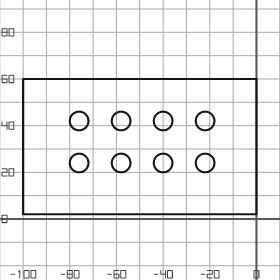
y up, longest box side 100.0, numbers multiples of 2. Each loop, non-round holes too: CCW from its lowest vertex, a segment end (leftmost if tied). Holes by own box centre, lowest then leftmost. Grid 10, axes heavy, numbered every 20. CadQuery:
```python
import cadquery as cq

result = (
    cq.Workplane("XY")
    .moveTo(-100.0, 2.0)
    .lineTo(0.0, 2.0)
    .lineTo(0.0, 60.0)
    .lineTo(-100.0, 60.0)
    .close()
    .moveTo(-76.0, 24.0)
    .circle(4.0)
    .moveTo(-58.0, 24.0)
    .circle(4.0)
    .moveTo(-40.0, 24.0)
    .circle(4.0)
    .moveTo(-22.0, 24.0)
    .circle(4.0)
    .moveTo(-76.0, 42.0)
    .circle(4.0)
    .moveTo(-58.0, 42.0)
    .circle(4.0)
    .moveTo(-40.0, 42.0)
    .circle(4.0)
    .moveTo(-22.0, 42.0)
    .circle(4.0)
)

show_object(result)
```